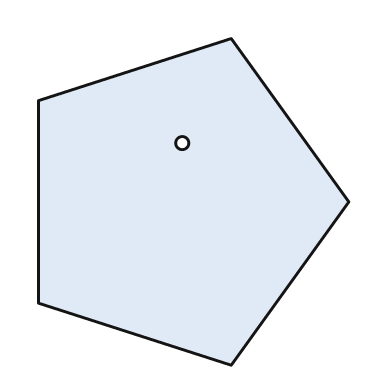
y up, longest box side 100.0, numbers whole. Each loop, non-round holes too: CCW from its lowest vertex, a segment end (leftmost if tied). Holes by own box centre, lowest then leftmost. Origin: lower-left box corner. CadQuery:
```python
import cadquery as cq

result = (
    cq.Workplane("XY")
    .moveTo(59.0, 0.0)
    .lineTo(95.0, 50.0)
    .lineTo(59.0, 100.0)
    .lineTo(0.0, 81.0)
    .lineTo(0.0, 19.0)
    .close()
    .moveTo(44.0, 68.0)
    .circle(2.0)
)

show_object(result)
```